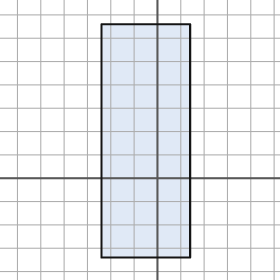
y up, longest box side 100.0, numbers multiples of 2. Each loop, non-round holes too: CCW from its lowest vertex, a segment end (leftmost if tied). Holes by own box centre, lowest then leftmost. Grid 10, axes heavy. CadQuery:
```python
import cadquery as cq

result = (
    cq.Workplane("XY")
    .moveTo(-24.0, -34.0)
    .lineTo(14.0, -34.0)
    .lineTo(14.0, 66.0)
    .lineTo(-24.0, 66.0)
    .close()
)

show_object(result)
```